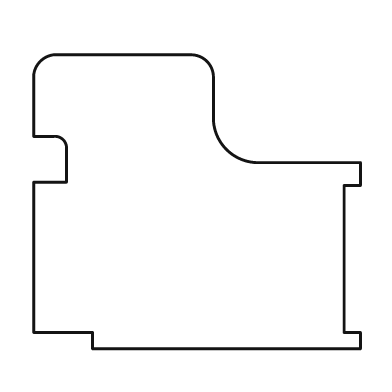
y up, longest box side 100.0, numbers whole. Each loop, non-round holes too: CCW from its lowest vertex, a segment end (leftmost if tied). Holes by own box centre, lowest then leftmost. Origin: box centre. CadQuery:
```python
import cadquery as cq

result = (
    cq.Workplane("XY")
    .moveTo(-32.0, -45.0)
    .lineTo(50.0, -45.0)
    .lineTo(50.0, -40.0)
    .lineTo(45.0, -40.0)
    .lineTo(45.0, 5.0)
    .lineTo(50.0, 5.0)
    .lineTo(50.0, 12.0)
    .lineTo(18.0, 12.0)
    .threePointArc((9.0, 16.0), (5.0, 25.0))
    .lineTo(5.0, 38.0)
    .threePointArc((3.0, 43.0), (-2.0, 45.0))
    .lineTo(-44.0, 45.0)
    .threePointArc((-48.0, 43.0), (-50.0, 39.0))
    .lineTo(-50.0, 20.0)
    .lineTo(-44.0, 20.0)
    .threePointArc((-41.0, 19.0), (-40.0, 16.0))
    .lineTo(-40.0, 6.0)
    .lineTo(-50.0, 6.0)
    .lineTo(-50.0, -40.0)
    .lineTo(-32.0, -40.0)
    .close()
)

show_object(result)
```